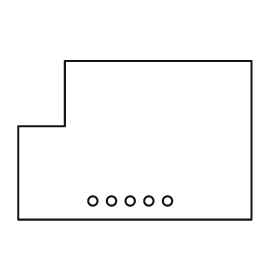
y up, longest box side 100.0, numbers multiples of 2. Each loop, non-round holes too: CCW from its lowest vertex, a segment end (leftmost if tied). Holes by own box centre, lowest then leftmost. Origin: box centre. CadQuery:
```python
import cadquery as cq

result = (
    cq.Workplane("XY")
    .moveTo(-50.0, -34.0)
    .lineTo(50.0, -34.0)
    .lineTo(50.0, 34.0)
    .lineTo(-30.0, 34.0)
    .lineTo(-30.0, 6.0)
    .lineTo(-50.0, 6.0)
    .close()
    .moveTo(-18.0, -26.0)
    .circle(2.0)
    .moveTo(-10.0, -26.0)
    .circle(2.0)
    .moveTo(-2.0, -26.0)
    .circle(2.0)
    .moveTo(6.0, -26.0)
    .circle(2.0)
    .moveTo(14.0, -26.0)
    .circle(2.0)
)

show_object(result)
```